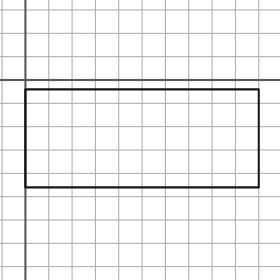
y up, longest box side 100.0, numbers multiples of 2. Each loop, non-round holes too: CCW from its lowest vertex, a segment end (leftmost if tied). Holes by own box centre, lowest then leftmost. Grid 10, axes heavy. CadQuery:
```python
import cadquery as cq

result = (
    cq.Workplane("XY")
    .moveTo(0.0, -46.0)
    .lineTo(100.0, -46.0)
    .lineTo(100.0, -4.0)
    .lineTo(0.0, -4.0)
    .close()
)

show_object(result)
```